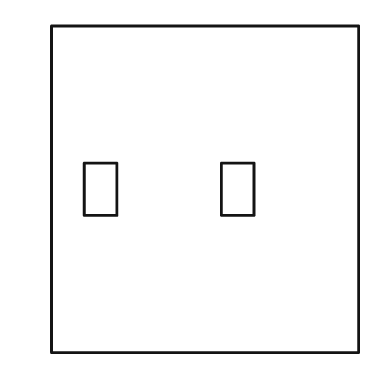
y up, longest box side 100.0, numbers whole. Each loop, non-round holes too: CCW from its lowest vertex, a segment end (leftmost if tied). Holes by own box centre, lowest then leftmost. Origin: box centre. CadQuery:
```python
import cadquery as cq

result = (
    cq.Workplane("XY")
    .moveTo(-47.0, -50.0)
    .lineTo(47.0, -50.0)
    .lineTo(47.0, 50.0)
    .lineTo(-47.0, 50.0)
    .close()
    .moveTo(-37.0, -8.0)
    .lineTo(-27.0, -8.0)
    .lineTo(-27.0, 8.0)
    .lineTo(-37.0, 8.0)
    .close()
    .moveTo(5.0, -8.0)
    .lineTo(15.0, -8.0)
    .lineTo(15.0, 8.0)
    .lineTo(5.0, 8.0)
    .close()
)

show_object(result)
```